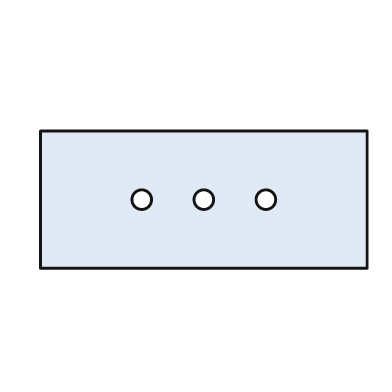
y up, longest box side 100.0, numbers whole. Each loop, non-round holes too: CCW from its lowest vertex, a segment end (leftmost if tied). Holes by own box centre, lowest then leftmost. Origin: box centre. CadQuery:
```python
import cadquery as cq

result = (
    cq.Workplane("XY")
    .moveTo(-50.0, -21.0)
    .lineTo(50.0, -21.0)
    .lineTo(50.0, 21.0)
    .lineTo(-50.0, 21.0)
    .close()
    .moveTo(-19.0, 0.0)
    .circle(3.0)
    .moveTo(0.0, 0.0)
    .circle(3.0)
    .moveTo(19.0, 0.0)
    .circle(3.0)
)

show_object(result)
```